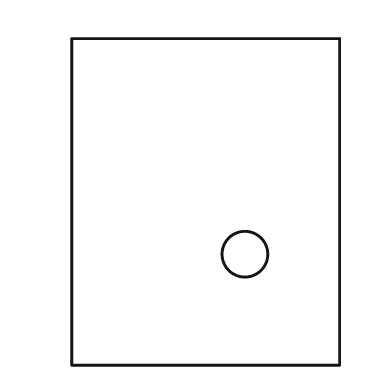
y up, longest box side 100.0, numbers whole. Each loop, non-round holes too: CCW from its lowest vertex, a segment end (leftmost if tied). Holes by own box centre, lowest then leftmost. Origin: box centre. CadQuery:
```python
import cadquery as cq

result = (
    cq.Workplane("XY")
    .moveTo(-41.0, -50.0)
    .lineTo(41.0, -50.0)
    .lineTo(41.0, 50.0)
    .lineTo(-41.0, 50.0)
    .close()
    .moveTo(12.0, -16.0)
    .circle(7.0)
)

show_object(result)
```